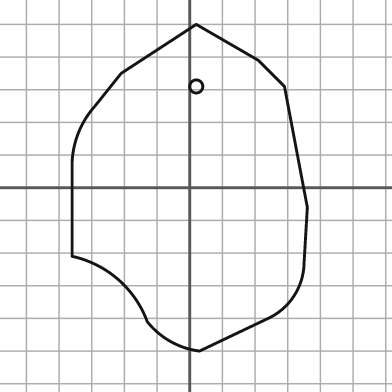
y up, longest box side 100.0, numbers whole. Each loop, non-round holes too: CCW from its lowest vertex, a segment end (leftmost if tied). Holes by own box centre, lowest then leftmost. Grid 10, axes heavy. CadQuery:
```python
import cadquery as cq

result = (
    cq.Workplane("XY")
    .moveTo(3.0, -50.0)
    .lineTo(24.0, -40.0)
    .threePointArc((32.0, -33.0), (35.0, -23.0))
    .lineTo(36.0, -6.0)
    .lineTo(29.0, 31.0)
    .lineTo(21.0, 39.0)
    .lineTo(2.0, 50.0)
    .lineTo(-21.0, 35.0)
    .lineTo(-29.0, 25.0)
    .threePointArc((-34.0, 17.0), (-36.0, 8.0))
    .lineTo(-36.0, -21.0)
    .threePointArc((-22.0, -28.0), (-13.0, -41.0))
    .threePointArc((-6.0, -47.0), (3.0, -50.0))
    .close()
    .moveTo(2.0, 31.0)
    .circle(2.0)
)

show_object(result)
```